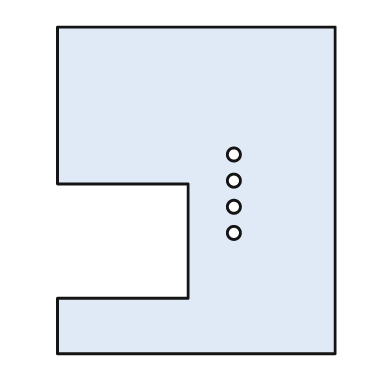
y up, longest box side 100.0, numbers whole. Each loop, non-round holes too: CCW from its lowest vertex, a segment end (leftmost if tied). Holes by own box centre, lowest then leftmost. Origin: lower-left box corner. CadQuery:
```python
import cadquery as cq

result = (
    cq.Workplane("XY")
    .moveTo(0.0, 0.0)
    .lineTo(85.0, 0.0)
    .lineTo(85.0, 100.0)
    .lineTo(0.0, 100.0)
    .lineTo(0.0, 52.0)
    .lineTo(40.0, 52.0)
    .lineTo(40.0, 17.0)
    .lineTo(0.0, 17.0)
    .close()
    .moveTo(54.0, 37.0)
    .circle(2.0)
    .moveTo(54.0, 45.0)
    .circle(2.0)
    .moveTo(54.0, 53.0)
    .circle(2.0)
    .moveTo(54.0, 61.0)
    .circle(2.0)
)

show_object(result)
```